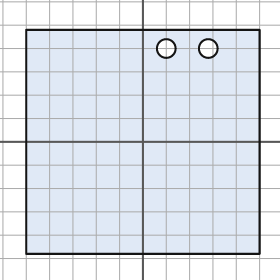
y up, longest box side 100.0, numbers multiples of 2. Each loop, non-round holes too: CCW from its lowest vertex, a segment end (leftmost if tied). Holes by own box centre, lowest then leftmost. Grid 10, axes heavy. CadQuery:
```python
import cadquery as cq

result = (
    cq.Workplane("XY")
    .moveTo(-50.0, -48.0)
    .lineTo(50.0, -48.0)
    .lineTo(50.0, 48.0)
    .lineTo(-50.0, 48.0)
    .close()
    .moveTo(10.0, 40.0)
    .circle(4.0)
    .moveTo(28.0, 40.0)
    .circle(4.0)
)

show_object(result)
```